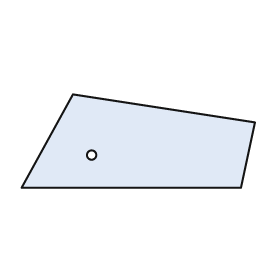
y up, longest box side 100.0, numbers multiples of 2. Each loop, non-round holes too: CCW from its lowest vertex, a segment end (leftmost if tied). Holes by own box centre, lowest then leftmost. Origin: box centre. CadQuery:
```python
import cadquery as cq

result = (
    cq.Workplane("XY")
    .moveTo(-50.0, -20.0)
    .lineTo(44.0, -20.0)
    .lineTo(50.0, 8.0)
    .lineTo(-28.0, 20.0)
    .close()
    .moveTo(-20.0, -6.0)
    .circle(2.0)
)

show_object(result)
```